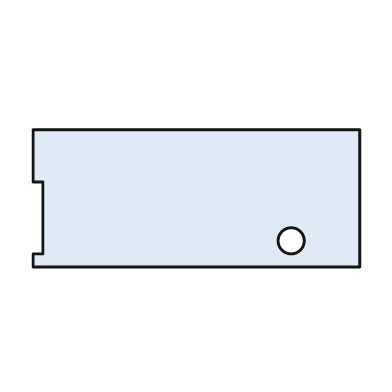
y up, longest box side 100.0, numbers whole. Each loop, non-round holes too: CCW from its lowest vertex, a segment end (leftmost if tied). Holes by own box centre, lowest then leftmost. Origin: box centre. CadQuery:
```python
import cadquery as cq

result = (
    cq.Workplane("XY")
    .moveTo(-50.0, -21.0)
    .lineTo(50.0, -21.0)
    .lineTo(50.0, 21.0)
    .lineTo(-50.0, 21.0)
    .lineTo(-50.0, 5.0)
    .lineTo(-47.0, 5.0)
    .lineTo(-47.0, -17.0)
    .lineTo(-50.0, -17.0)
    .close()
    .moveTo(29.0, -13.0)
    .circle(4.0)
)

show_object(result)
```